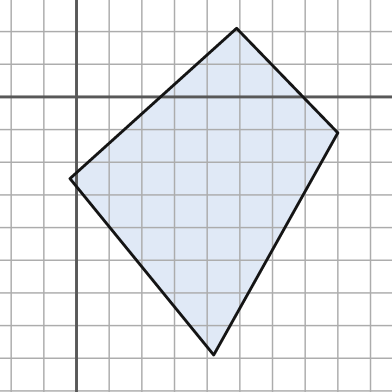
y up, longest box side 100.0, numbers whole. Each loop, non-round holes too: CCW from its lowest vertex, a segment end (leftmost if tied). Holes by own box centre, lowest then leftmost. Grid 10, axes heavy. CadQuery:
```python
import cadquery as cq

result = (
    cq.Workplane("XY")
    .moveTo(42.0, -79.0)
    .lineTo(80.0, -11.0)
    .lineTo(49.0, 21.0)
    .lineTo(-2.0, -25.0)
    .close()
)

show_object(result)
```